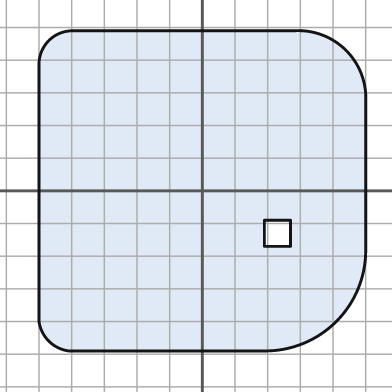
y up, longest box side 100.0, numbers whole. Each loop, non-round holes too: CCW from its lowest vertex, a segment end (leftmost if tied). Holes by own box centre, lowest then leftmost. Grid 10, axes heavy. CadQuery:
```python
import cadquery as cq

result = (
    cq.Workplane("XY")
    .moveTo(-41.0, -49.0)
    .lineTo(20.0, -49.0)
    .threePointArc((41.0, -40.0), (50.0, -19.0))
    .lineTo(50.0, 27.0)
    .threePointArc((44.0, 43.0), (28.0, 49.0))
    .lineTo(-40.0, 49.0)
    .threePointArc((-47.0, 46.0), (-50.0, 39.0))
    .lineTo(-50.0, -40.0)
    .threePointArc((-47.0, -46.0), (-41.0, -49.0))
    .close()
    .moveTo(19.0, -17.0)
    .lineTo(27.0, -17.0)
    .lineTo(27.0, -9.0)
    .lineTo(19.0, -9.0)
    .close()
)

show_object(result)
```